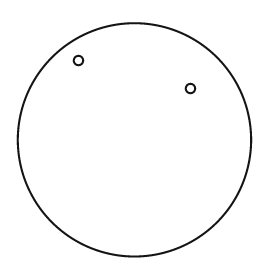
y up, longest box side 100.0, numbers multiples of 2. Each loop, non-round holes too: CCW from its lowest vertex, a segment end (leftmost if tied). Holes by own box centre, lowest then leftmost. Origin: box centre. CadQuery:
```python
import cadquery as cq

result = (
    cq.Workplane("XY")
    .moveTo(0.0, 0.0)
    .circle(50.0)
    .moveTo(24.0, 22.0)
    .circle(2.0)
    .moveTo(-24.0, 34.0)
    .circle(2.0)
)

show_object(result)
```